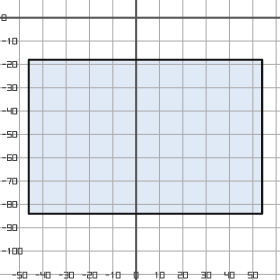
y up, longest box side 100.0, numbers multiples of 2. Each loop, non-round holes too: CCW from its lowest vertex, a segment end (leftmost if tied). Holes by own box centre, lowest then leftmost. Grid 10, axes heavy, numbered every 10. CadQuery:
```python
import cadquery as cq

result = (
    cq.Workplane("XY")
    .moveTo(-46.0, -84.0)
    .lineTo(54.0, -84.0)
    .lineTo(54.0, -18.0)
    .lineTo(-46.0, -18.0)
    .close()
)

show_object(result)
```